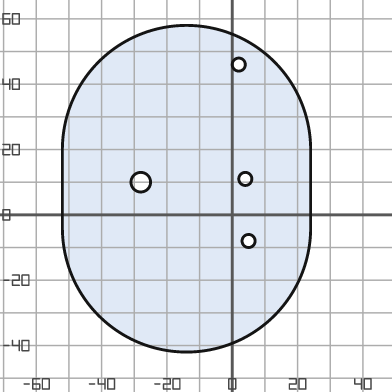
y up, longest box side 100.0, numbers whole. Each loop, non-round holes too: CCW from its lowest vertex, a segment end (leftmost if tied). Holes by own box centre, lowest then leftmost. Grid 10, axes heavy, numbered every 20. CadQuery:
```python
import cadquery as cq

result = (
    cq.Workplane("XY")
    .moveTo(-52.0, -4.0)
    .threePointArc((-14.0, -42.0), (24.0, -4.0))
    .lineTo(24.0, 20.0)
    .threePointArc((-14.0, 58.0), (-52.0, 20.0))
    .close()
    .moveTo(5.0, -8.0)
    .circle(2.0)
    .moveTo(-28.0, 10.0)
    .circle(3.0)
    .moveTo(4.0, 11.0)
    .circle(2.0)
    .moveTo(2.0, 46.0)
    .circle(2.0)
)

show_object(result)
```